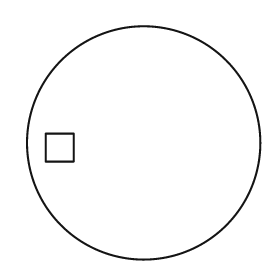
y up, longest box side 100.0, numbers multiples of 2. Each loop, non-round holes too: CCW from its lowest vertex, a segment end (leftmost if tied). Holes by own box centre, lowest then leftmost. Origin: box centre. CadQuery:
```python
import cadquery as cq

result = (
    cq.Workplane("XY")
    .moveTo(0.0, 0.0)
    .circle(50.0)
    .moveTo(-42.0, -8.0)
    .lineTo(-30.0, -8.0)
    .lineTo(-30.0, 4.0)
    .lineTo(-42.0, 4.0)
    .close()
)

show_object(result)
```